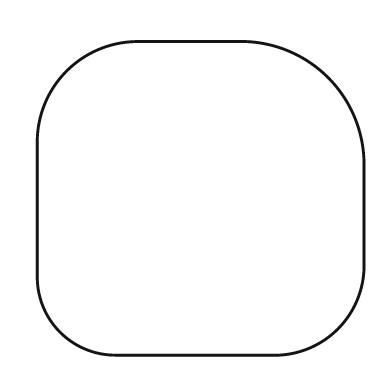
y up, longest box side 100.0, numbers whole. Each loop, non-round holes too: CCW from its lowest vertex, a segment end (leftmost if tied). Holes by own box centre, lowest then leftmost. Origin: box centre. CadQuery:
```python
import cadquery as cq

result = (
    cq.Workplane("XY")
    .moveTo(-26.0, -48.0)
    .lineTo(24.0, -48.0)
    .threePointArc((42.0, -40.0), (50.0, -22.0))
    .lineTo(50.0, 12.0)
    .threePointArc((39.0, 37.0), (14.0, 48.0))
    .lineTo(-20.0, 48.0)
    .threePointArc((-41.0, 39.0), (-50.0, 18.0))
    .lineTo(-50.0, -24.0)
    .threePointArc((-43.0, -41.0), (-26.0, -48.0))
    .close()
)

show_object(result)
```